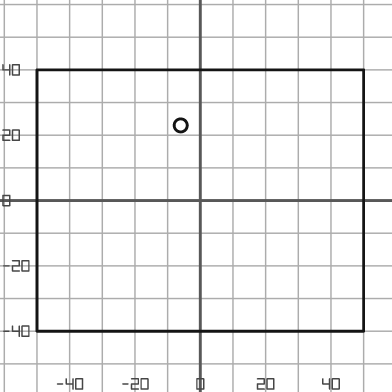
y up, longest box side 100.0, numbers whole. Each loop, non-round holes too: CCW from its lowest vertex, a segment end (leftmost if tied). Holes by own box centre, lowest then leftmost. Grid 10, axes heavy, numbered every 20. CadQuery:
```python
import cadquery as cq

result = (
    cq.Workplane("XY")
    .moveTo(-50.0, -40.0)
    .lineTo(50.0, -40.0)
    .lineTo(50.0, 40.0)
    .lineTo(-50.0, 40.0)
    .close()
    .moveTo(-6.0, 23.0)
    .circle(2.0)
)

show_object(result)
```